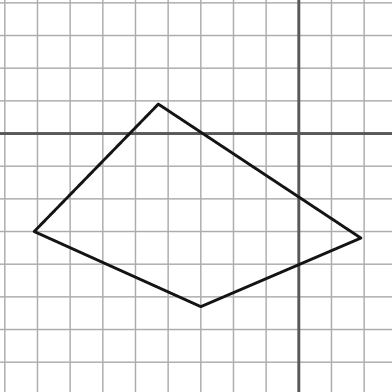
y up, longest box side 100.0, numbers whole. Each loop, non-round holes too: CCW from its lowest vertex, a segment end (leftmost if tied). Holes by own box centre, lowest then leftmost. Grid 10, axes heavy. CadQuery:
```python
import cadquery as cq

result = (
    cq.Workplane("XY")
    .moveTo(-30.0, -53.0)
    .lineTo(19.0, -32.0)
    .lineTo(-43.0, 9.0)
    .lineTo(-81.0, -30.0)
    .close()
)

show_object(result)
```